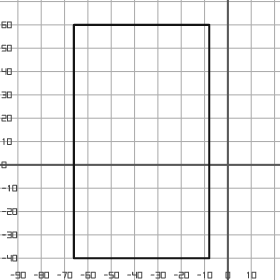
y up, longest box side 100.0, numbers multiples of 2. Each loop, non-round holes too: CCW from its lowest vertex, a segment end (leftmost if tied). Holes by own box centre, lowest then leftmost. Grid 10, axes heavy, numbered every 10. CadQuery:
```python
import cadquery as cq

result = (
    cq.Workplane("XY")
    .moveTo(-66.0, -40.0)
    .lineTo(-8.0, -40.0)
    .lineTo(-8.0, 60.0)
    .lineTo(-66.0, 60.0)
    .close()
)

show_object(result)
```